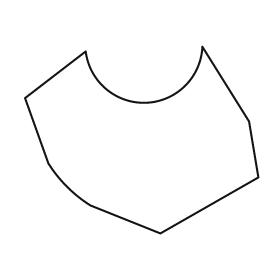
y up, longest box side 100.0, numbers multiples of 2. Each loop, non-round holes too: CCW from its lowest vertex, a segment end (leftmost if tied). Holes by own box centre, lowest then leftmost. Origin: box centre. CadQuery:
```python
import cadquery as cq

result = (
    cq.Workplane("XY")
    .moveTo(8.0, -40.0)
    .lineTo(50.0, -16.0)
    .lineTo(46.0, 8.0)
    .lineTo(26.0, 40.0)
    .threePointArc((2.0, 16.0), (-24.0, 38.0))
    .lineTo(-50.0, 18.0)
    .lineTo(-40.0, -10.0)
    .threePointArc((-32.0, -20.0), (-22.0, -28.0))
    .close()
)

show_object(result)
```